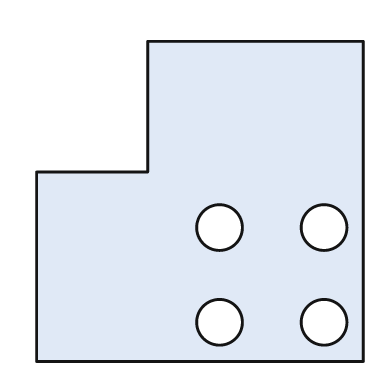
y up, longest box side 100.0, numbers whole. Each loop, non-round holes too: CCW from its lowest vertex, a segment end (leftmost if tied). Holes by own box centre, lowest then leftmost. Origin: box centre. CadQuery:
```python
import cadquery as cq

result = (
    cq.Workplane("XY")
    .moveTo(-50.0, -49.0)
    .lineTo(50.0, -49.0)
    .lineTo(50.0, 49.0)
    .lineTo(-16.0, 49.0)
    .lineTo(-16.0, 9.0)
    .lineTo(-50.0, 9.0)
    .close()
    .moveTo(6.0, -37.0)
    .circle(7.0)
    .moveTo(38.0, -37.0)
    .circle(7.0)
    .moveTo(6.0, -8.0)
    .circle(7.0)
    .moveTo(38.0, -8.0)
    .circle(7.0)
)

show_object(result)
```